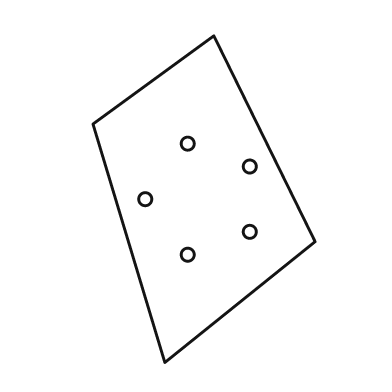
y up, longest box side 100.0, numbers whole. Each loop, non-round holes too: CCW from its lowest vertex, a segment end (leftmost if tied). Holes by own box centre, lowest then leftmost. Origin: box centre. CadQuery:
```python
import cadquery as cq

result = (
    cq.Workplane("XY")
    .moveTo(-12.0, -50.0)
    .lineTo(34.0, -13.0)
    .lineTo(3.0, 50.0)
    .lineTo(-34.0, 23.0)
    .close()
    .moveTo(-5.0, -17.0)
    .circle(2.0)
    .moveTo(14.0, -10.0)
    .circle(2.0)
    .moveTo(-18.0, 0.0)
    .circle(2.0)
    .moveTo(14.0, 10.0)
    .circle(2.0)
    .moveTo(-5.0, 17.0)
    .circle(2.0)
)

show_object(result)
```